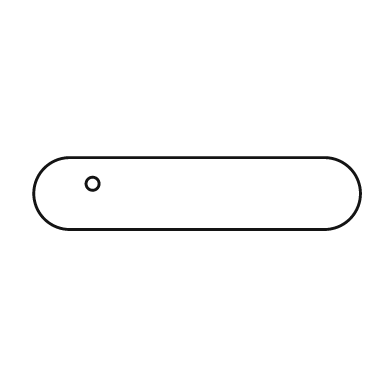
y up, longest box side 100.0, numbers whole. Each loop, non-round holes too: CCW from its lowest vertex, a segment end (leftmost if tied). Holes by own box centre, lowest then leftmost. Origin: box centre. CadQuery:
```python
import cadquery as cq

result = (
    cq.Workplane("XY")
    .moveTo(-39.0, -11.0)
    .lineTo(39.0, -11.0)
    .threePointArc((50.0, 0.0), (39.0, 11.0))
    .lineTo(-39.0, 11.0)
    .threePointArc((-50.0, 0.0), (-39.0, -11.0))
    .close()
    .moveTo(-32.0, 3.0)
    .circle(2.0)
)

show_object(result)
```